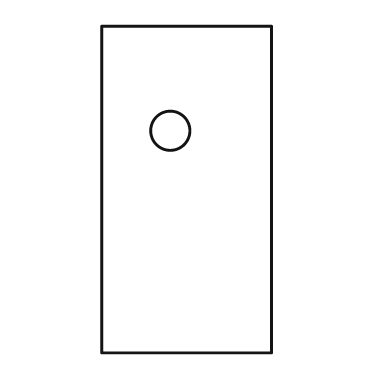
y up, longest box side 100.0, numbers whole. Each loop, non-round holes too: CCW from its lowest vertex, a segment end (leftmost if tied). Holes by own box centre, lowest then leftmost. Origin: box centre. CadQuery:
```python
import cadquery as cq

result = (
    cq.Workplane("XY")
    .moveTo(-26.0, -50.0)
    .lineTo(26.0, -50.0)
    .lineTo(26.0, 50.0)
    .lineTo(-26.0, 50.0)
    .close()
    .moveTo(-5.0, 18.0)
    .circle(6.0)
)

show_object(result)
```